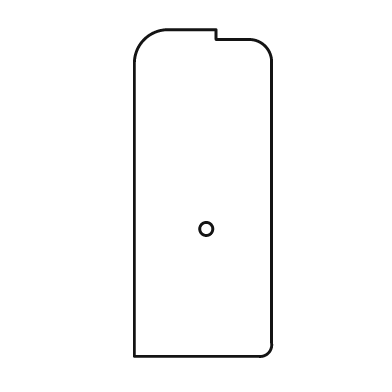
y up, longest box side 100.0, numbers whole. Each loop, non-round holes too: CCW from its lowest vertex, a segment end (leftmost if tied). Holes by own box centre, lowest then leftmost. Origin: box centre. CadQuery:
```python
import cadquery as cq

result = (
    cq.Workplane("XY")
    .moveTo(-21.0, -50.0)
    .lineTo(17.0, -50.0)
    .threePointArc((20.0, -49.0), (21.0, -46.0))
    .lineTo(21.0, 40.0)
    .threePointArc((19.0, 45.0), (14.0, 47.0))
    .lineTo(4.0, 47.0)
    .lineTo(4.0, 50.0)
    .lineTo(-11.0, 50.0)
    .threePointArc((-18.0, 47.0), (-21.0, 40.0))
    .close()
    .moveTo(1.0, -11.0)
    .circle(2.0)
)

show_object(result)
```